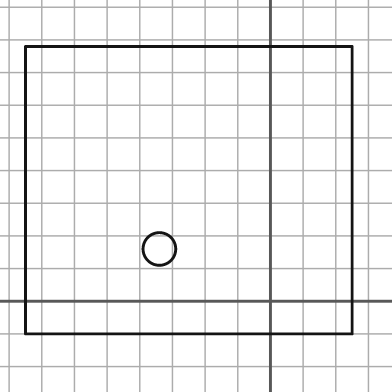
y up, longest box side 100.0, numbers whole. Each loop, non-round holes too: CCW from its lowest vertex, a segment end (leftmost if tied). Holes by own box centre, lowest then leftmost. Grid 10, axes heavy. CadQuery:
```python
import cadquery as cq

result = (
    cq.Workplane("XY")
    .moveTo(-75.0, -10.0)
    .lineTo(25.0, -10.0)
    .lineTo(25.0, 78.0)
    .lineTo(-75.0, 78.0)
    .close()
    .moveTo(-34.0, 16.0)
    .circle(5.0)
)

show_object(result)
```